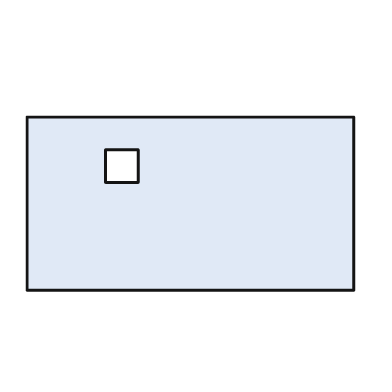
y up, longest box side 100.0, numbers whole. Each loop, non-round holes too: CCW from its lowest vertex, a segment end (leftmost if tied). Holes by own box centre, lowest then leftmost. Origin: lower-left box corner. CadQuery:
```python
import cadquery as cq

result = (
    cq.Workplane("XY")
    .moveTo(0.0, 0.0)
    .lineTo(100.0, 0.0)
    .lineTo(100.0, 53.0)
    .lineTo(0.0, 53.0)
    .close()
    .moveTo(24.0, 33.0)
    .lineTo(34.0, 33.0)
    .lineTo(34.0, 43.0)
    .lineTo(24.0, 43.0)
    .close()
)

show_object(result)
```